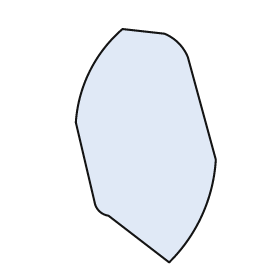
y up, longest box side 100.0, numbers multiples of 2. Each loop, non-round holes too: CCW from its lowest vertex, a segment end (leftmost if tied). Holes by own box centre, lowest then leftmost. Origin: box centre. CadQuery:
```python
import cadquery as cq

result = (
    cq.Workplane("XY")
    .moveTo(10.0, -50.0)
    .threePointArc((24.0, -30.0), (30.0, -6.0))
    .lineTo(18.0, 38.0)
    .threePointArc((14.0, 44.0), (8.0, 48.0))
    .lineTo(-10.0, 50.0)
    .threePointArc((-24.0, 32.0), (-30.0, 10.0))
    .lineTo(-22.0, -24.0)
    .threePointArc((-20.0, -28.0), (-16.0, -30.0))
    .close()
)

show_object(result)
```